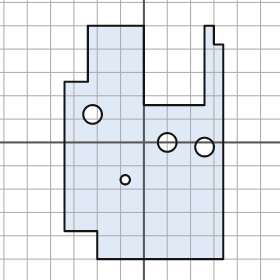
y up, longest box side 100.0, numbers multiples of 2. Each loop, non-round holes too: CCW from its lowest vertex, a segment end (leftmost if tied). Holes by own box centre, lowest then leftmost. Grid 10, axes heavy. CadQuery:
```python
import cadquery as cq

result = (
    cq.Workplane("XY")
    .moveTo(-20.0, -50.0)
    .lineTo(34.0, -50.0)
    .lineTo(34.0, 42.0)
    .lineTo(30.0, 42.0)
    .lineTo(30.0, 50.0)
    .lineTo(26.0, 50.0)
    .lineTo(26.0, 16.0)
    .lineTo(0.0, 16.0)
    .lineTo(0.0, 50.0)
    .lineTo(-24.0, 50.0)
    .lineTo(-24.0, 26.0)
    .lineTo(-34.0, 26.0)
    .lineTo(-34.0, -38.0)
    .lineTo(-20.0, -38.0)
    .close()
    .moveTo(-8.0, -16.0)
    .circle(2.0)
    .moveTo(26.0, -2.0)
    .circle(4.0)
    .moveTo(10.0, 0.0)
    .circle(4.0)
    .moveTo(-22.0, 12.0)
    .circle(4.0)
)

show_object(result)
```